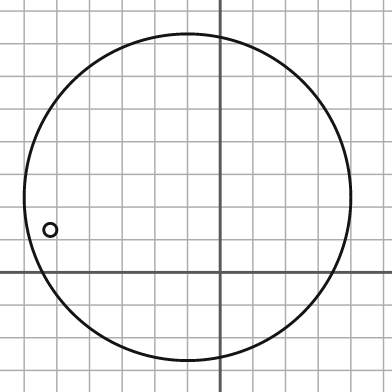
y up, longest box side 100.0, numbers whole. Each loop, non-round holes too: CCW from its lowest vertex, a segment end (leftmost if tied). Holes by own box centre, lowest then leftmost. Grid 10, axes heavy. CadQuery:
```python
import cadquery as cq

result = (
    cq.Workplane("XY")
    .moveTo(-10.0, 23.0)
    .circle(50.0)
    .moveTo(-52.0, 13.0)
    .circle(2.0)
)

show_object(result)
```